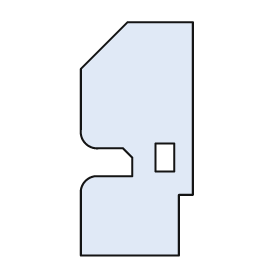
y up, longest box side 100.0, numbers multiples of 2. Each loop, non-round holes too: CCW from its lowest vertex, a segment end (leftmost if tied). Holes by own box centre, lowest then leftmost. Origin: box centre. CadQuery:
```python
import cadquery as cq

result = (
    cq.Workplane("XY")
    .moveTo(-24.0, -50.0)
    .lineTo(18.0, -50.0)
    .lineTo(18.0, -24.0)
    .lineTo(24.0, -24.0)
    .lineTo(24.0, 50.0)
    .lineTo(-4.0, 50.0)
    .lineTo(-24.0, 30.0)
    .lineTo(-24.0, 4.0)
    .threePointArc((-22.0, -2.0), (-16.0, -4.0))
    .lineTo(-6.0, -4.0)
    .lineTo(-2.0, -8.0)
    .lineTo(-2.0, -16.0)
    .lineTo(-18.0, -16.0)
    .threePointArc((-22.0, -18.0), (-24.0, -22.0))
    .close()
    .moveTo(8.0, -14.0)
    .lineTo(16.0, -14.0)
    .lineTo(16.0, -2.0)
    .lineTo(8.0, -2.0)
    .close()
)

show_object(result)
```